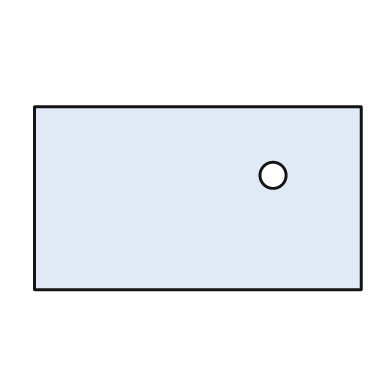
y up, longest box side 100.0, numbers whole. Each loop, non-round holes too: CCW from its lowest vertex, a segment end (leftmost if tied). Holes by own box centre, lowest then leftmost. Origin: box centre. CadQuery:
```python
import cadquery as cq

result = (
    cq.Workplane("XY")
    .moveTo(-50.0, -28.0)
    .lineTo(50.0, -28.0)
    .lineTo(50.0, 28.0)
    .lineTo(-50.0, 28.0)
    .close()
    .moveTo(23.0, 7.0)
    .circle(4.0)
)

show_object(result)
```